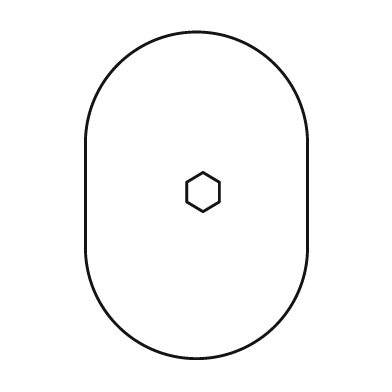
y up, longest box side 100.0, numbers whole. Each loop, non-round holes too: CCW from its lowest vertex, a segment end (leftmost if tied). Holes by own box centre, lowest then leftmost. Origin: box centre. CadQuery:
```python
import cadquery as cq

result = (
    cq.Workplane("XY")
    .moveTo(-34.0, -16.0)
    .threePointArc((0.0, -50.0), (34.0, -16.0))
    .lineTo(34.0, 16.0)
    .threePointArc((0.0, 50.0), (-34.0, 16.0))
    .close()
    .moveTo(2.0, -5.0)
    .lineTo(7.0, -2.0)
    .lineTo(7.0, 4.0)
    .lineTo(2.0, 7.0)
    .lineTo(-3.0, 4.0)
    .lineTo(-3.0, -2.0)
    .close()
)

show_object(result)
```